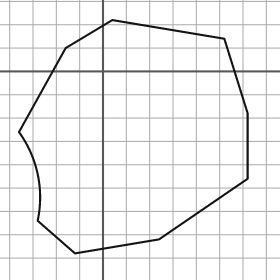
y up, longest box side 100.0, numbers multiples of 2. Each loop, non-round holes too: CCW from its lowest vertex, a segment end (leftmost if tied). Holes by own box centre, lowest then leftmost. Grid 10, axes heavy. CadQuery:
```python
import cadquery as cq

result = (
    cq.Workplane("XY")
    .moveTo(-12.0, -78.0)
    .lineTo(24.0, -72.0)
    .lineTo(62.0, -46.0)
    .lineTo(62.0, -18.0)
    .lineTo(52.0, 14.0)
    .lineTo(4.0, 22.0)
    .lineTo(-16.0, 10.0)
    .lineTo(-36.0, -26.0)
    .threePointArc((-28.0, -44.0), (-28.0, -64.0))
    .close()
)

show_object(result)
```